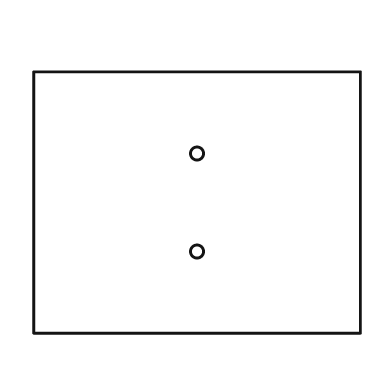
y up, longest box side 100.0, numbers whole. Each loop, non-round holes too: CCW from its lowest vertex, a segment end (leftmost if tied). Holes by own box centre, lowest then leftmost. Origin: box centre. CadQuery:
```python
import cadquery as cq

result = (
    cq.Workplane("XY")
    .moveTo(-50.0, -40.0)
    .lineTo(50.0, -40.0)
    .lineTo(50.0, 40.0)
    .lineTo(-50.0, 40.0)
    .close()
    .moveTo(0.0, -15.0)
    .circle(2.0)
    .moveTo(0.0, 15.0)
    .circle(2.0)
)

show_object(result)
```